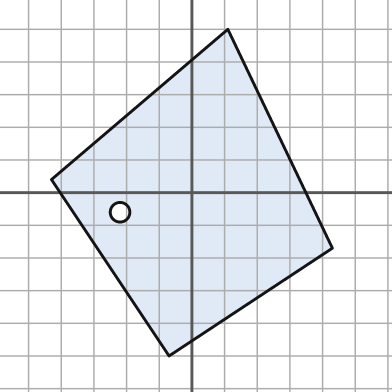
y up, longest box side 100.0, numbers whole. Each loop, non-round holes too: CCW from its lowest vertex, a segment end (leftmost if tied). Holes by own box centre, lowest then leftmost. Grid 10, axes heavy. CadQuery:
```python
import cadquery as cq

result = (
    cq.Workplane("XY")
    .moveTo(-7.0, -50.0)
    .lineTo(43.0, -17.0)
    .lineTo(11.0, 50.0)
    .lineTo(-43.0, 4.0)
    .close()
    .moveTo(-22.0, -6.0)
    .circle(3.0)
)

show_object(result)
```